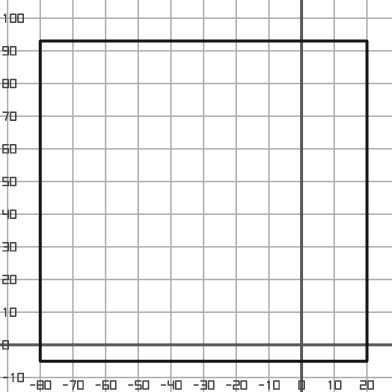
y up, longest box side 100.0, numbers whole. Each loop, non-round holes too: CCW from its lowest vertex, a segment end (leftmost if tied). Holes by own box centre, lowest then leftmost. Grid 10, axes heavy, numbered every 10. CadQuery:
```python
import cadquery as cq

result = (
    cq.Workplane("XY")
    .moveTo(-80.0, -5.0)
    .lineTo(20.0, -5.0)
    .lineTo(20.0, 93.0)
    .lineTo(-80.0, 93.0)
    .close()
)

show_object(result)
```